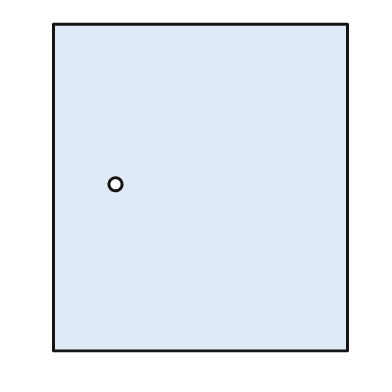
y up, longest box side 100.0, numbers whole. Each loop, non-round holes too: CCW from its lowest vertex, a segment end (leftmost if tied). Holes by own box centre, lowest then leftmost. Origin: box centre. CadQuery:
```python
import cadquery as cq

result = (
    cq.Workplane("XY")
    .moveTo(-45.0, -50.0)
    .lineTo(45.0, -50.0)
    .lineTo(45.0, 50.0)
    .lineTo(-45.0, 50.0)
    .close()
    .moveTo(-26.0, 1.0)
    .circle(2.0)
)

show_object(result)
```